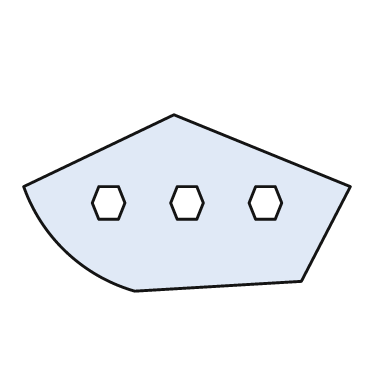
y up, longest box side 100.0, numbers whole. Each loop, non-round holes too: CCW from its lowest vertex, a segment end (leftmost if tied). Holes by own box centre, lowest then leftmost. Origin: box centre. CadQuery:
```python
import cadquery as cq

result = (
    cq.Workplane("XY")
    .moveTo(-16.0, -27.0)
    .lineTo(35.0, -24.0)
    .lineTo(50.0, 5.0)
    .lineTo(-4.0, 27.0)
    .lineTo(-50.0, 5.0)
    .threePointArc((-37.0, -15.0), (-16.0, -27.0))
    .close()
    .moveTo(-27.0, -5.0)
    .lineTo(-21.0, -5.0)
    .lineTo(-19.0, 0.0)
    .lineTo(-21.0, 5.0)
    .lineTo(-27.0, 5.0)
    .lineTo(-29.0, 0.0)
    .close()
    .moveTo(-3.0, -5.0)
    .lineTo(3.0, -5.0)
    .lineTo(5.0, 0.0)
    .lineTo(3.0, 5.0)
    .lineTo(-3.0, 5.0)
    .lineTo(-5.0, 0.0)
    .close()
    .moveTo(21.0, -5.0)
    .lineTo(27.0, -5.0)
    .lineTo(29.0, 0.0)
    .lineTo(27.0, 5.0)
    .lineTo(21.0, 5.0)
    .lineTo(19.0, 0.0)
    .close()
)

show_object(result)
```